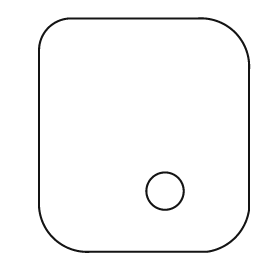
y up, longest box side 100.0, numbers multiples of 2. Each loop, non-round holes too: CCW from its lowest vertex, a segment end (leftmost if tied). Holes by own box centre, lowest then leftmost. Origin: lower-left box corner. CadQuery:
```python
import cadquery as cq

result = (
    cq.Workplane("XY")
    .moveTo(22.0, 0.0)
    .lineTo(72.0, 0.0)
    .threePointArc((84.0, 6.0), (90.0, 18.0))
    .lineTo(90.0, 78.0)
    .threePointArc((84.0, 94.0), (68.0, 100.0))
    .lineTo(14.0, 100.0)
    .threePointArc((4.0, 96.0), (0.0, 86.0))
    .lineTo(0.0, 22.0)
    .threePointArc((6.0, 6.0), (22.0, 0.0))
    .close()
    .moveTo(54.0, 26.0)
    .circle(8.0)
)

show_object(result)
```